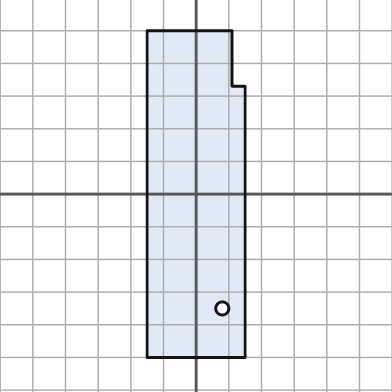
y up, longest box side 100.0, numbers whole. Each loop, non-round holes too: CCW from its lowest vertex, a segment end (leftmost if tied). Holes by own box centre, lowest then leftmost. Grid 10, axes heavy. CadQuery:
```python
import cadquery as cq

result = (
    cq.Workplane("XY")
    .moveTo(-15.0, -50.0)
    .lineTo(15.0, -50.0)
    .lineTo(15.0, 33.0)
    .lineTo(11.0, 33.0)
    .lineTo(11.0, 50.0)
    .lineTo(-15.0, 50.0)
    .close()
    .moveTo(8.0, -35.0)
    .circle(2.0)
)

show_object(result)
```